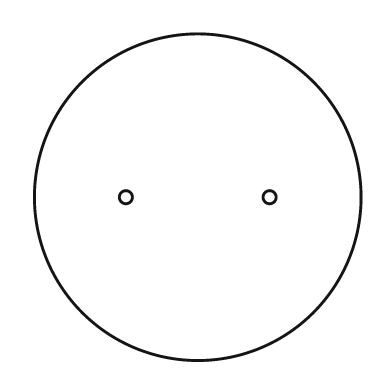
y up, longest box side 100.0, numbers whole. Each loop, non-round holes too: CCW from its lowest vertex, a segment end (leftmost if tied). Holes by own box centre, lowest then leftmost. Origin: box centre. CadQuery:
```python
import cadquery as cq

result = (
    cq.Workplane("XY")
    .moveTo(0.0, 0.0)
    .circle(50.0)
    .moveTo(-22.0, 0.0)
    .circle(2.0)
    .moveTo(22.0, 0.0)
    .circle(2.0)
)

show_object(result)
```